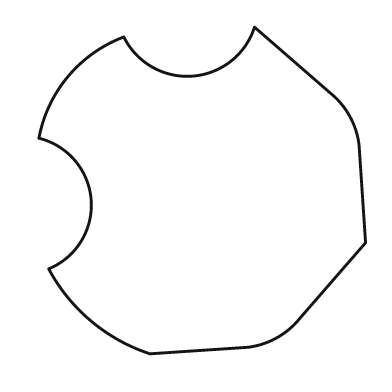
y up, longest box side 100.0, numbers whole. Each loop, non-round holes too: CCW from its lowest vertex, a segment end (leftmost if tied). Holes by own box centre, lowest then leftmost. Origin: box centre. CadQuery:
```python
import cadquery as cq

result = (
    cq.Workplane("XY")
    .moveTo(-16.0, -50.0)
    .lineTo(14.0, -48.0)
    .threePointArc((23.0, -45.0), (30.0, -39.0))
    .lineTo(50.0, -16.0)
    .lineTo(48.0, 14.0)
    .threePointArc((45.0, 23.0), (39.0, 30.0))
    .lineTo(16.0, 50.0)
    .threePointArc((-3.0, 35.0), (-24.0, 47.0))
    .threePointArc((-41.0, 35.0), (-50.0, 16.0))
    .threePointArc((-34.0, -3.0), (-47.0, -24.0))
    .threePointArc((-34.0, -40.0), (-16.0, -50.0))
    .close()
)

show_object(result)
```